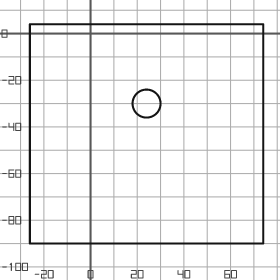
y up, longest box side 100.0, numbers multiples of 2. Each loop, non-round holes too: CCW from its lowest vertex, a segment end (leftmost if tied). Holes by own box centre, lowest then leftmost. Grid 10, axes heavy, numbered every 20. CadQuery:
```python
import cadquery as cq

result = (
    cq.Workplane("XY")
    .moveTo(-26.0, -90.0)
    .lineTo(74.0, -90.0)
    .lineTo(74.0, 4.0)
    .lineTo(-26.0, 4.0)
    .close()
    .moveTo(24.0, -30.0)
    .circle(6.0)
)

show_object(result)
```